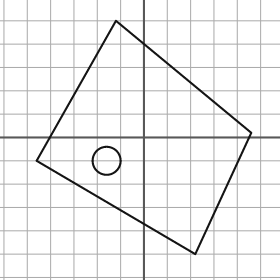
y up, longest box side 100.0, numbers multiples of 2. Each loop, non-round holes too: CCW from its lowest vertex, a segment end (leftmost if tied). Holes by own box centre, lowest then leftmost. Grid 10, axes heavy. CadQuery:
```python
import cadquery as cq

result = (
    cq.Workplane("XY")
    .moveTo(22.0, -50.0)
    .lineTo(46.0, 2.0)
    .lineTo(-12.0, 50.0)
    .lineTo(-46.0, -10.0)
    .close()
    .moveTo(-16.0, -10.0)
    .circle(6.0)
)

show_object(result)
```